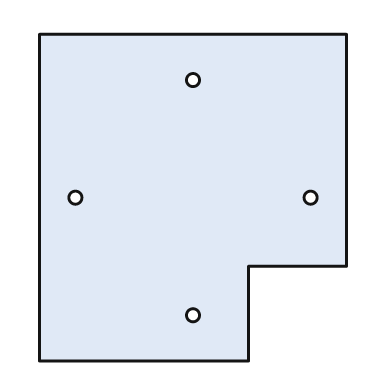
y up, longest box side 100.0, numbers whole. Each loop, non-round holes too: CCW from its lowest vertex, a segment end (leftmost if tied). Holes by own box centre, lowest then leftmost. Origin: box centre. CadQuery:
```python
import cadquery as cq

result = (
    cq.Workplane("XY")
    .moveTo(-47.0, -50.0)
    .lineTo(17.0, -50.0)
    .lineTo(17.0, -21.0)
    .lineTo(47.0, -21.0)
    .lineTo(47.0, 50.0)
    .lineTo(-47.0, 50.0)
    .close()
    .moveTo(0.0, -36.0)
    .circle(2.0)
    .moveTo(-36.0, 0.0)
    .circle(2.0)
    .moveTo(36.0, 0.0)
    .circle(2.0)
    .moveTo(0.0, 36.0)
    .circle(2.0)
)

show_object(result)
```